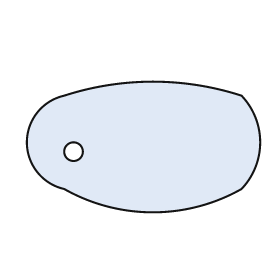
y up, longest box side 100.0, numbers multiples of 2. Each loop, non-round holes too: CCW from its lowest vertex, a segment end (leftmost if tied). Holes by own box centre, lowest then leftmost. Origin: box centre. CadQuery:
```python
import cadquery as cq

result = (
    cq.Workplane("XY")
    .moveTo(-34.0, -18.0)
    .threePointArc((4.0, -28.0), (42.0, -18.0))
    .threePointArc((50.0, 2.0), (42.0, 22.0))
    .threePointArc((4.0, 28.0), (-34.0, 22.0))
    .threePointArc((-50.0, 2.0), (-34.0, -18.0))
    .close()
    .moveTo(-30.0, -2.0)
    .circle(4.0)
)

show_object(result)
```